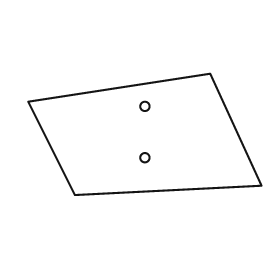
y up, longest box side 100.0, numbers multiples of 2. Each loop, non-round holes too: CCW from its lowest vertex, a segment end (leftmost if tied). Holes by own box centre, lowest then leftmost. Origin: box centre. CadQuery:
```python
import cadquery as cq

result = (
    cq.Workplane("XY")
    .moveTo(-30.0, -26.0)
    .lineTo(50.0, -22.0)
    .lineTo(28.0, 26.0)
    .lineTo(-50.0, 14.0)
    .close()
    .moveTo(0.0, -10.0)
    .circle(2.0)
    .moveTo(0.0, 12.0)
    .circle(2.0)
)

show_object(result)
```